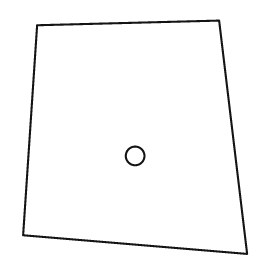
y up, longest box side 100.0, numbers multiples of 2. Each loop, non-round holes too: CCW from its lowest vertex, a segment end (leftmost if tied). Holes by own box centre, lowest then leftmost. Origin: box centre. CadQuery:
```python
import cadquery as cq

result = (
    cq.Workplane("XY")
    .moveTo(48.0, -50.0)
    .lineTo(36.0, 50.0)
    .lineTo(-42.0, 48.0)
    .lineTo(-48.0, -42.0)
    .close()
    .moveTo(0.0, -8.0)
    .circle(4.0)
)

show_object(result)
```